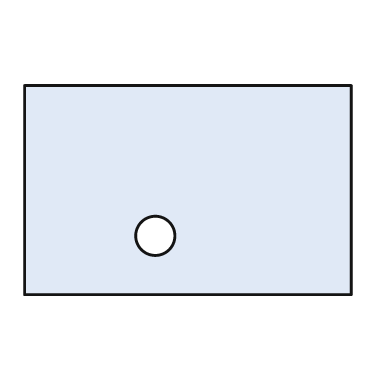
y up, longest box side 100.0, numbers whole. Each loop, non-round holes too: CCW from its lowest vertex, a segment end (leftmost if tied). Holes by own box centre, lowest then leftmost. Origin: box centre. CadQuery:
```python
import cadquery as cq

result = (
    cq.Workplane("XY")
    .moveTo(-50.0, -32.0)
    .lineTo(50.0, -32.0)
    .lineTo(50.0, 32.0)
    .lineTo(-50.0, 32.0)
    .close()
    .moveTo(-10.0, -14.0)
    .circle(6.0)
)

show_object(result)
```